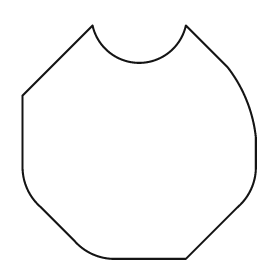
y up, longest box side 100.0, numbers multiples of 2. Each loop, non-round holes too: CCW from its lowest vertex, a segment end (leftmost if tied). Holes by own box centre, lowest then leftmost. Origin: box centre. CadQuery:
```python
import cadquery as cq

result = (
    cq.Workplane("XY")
    .moveTo(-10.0, -50.0)
    .lineTo(20.0, -50.0)
    .lineTo(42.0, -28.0)
    .threePointArc((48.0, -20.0), (50.0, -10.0))
    .lineTo(50.0, 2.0)
    .threePointArc((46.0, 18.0), (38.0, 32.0))
    .lineTo(20.0, 50.0)
    .threePointArc((0.0, 34.0), (-20.0, 50.0))
    .lineTo(-50.0, 20.0)
    .lineTo(-50.0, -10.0)
    .threePointArc((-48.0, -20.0), (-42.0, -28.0))
    .lineTo(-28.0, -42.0)
    .threePointArc((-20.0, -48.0), (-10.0, -50.0))
    .close()
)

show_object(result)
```